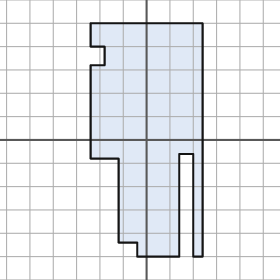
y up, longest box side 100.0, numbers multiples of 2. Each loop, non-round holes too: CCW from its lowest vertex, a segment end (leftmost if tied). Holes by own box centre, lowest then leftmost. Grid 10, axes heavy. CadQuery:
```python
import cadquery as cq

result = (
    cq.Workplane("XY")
    .moveTo(-4.0, -50.0)
    .lineTo(14.0, -50.0)
    .lineTo(14.0, -6.0)
    .lineTo(20.0, -6.0)
    .lineTo(20.0, -50.0)
    .lineTo(24.0, -50.0)
    .lineTo(24.0, 50.0)
    .lineTo(-24.0, 50.0)
    .lineTo(-24.0, 40.0)
    .lineTo(-18.0, 40.0)
    .lineTo(-18.0, 32.0)
    .lineTo(-24.0, 32.0)
    .lineTo(-24.0, -8.0)
    .lineTo(-12.0, -8.0)
    .lineTo(-12.0, -44.0)
    .lineTo(-4.0, -44.0)
    .close()
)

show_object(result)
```